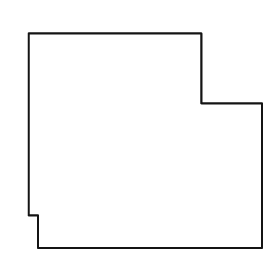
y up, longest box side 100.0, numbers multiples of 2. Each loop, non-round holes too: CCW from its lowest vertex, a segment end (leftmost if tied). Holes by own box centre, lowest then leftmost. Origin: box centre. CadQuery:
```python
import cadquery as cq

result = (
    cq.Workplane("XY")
    .moveTo(-46.0, -46.0)
    .lineTo(50.0, -46.0)
    .lineTo(50.0, 16.0)
    .lineTo(24.0, 16.0)
    .lineTo(24.0, 46.0)
    .lineTo(-50.0, 46.0)
    .lineTo(-50.0, -32.0)
    .lineTo(-46.0, -32.0)
    .close()
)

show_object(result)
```